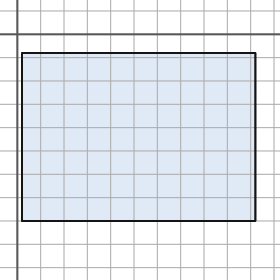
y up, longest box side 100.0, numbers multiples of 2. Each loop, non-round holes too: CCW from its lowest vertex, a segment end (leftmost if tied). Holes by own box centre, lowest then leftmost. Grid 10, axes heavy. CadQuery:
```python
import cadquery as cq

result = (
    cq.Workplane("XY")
    .moveTo(2.0, -80.0)
    .lineTo(102.0, -80.0)
    .lineTo(102.0, -8.0)
    .lineTo(2.0, -8.0)
    .close()
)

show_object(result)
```